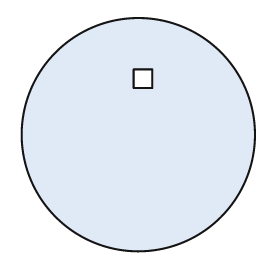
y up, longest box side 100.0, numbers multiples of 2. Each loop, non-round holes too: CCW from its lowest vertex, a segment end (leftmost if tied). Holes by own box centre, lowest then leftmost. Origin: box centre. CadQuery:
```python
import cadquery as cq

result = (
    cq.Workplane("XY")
    .moveTo(0.0, 0.0)
    .circle(50.0)
    .moveTo(-2.0, 20.0)
    .lineTo(6.0, 20.0)
    .lineTo(6.0, 28.0)
    .lineTo(-2.0, 28.0)
    .close()
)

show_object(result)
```